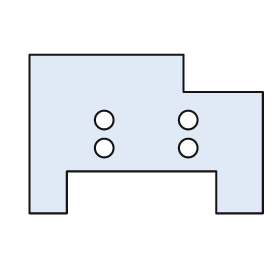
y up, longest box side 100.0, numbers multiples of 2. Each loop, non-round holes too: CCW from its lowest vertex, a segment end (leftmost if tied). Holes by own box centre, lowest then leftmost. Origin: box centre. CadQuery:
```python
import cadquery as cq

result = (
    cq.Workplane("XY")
    .moveTo(-50.0, -34.0)
    .lineTo(-34.0, -34.0)
    .lineTo(-34.0, -16.0)
    .lineTo(30.0, -16.0)
    .lineTo(30.0, -34.0)
    .lineTo(50.0, -34.0)
    .lineTo(50.0, 18.0)
    .lineTo(16.0, 18.0)
    .lineTo(16.0, 34.0)
    .lineTo(-50.0, 34.0)
    .close()
    .moveTo(-18.0, -6.0)
    .circle(4.0)
    .moveTo(18.0, -6.0)
    .circle(4.0)
    .moveTo(-18.0, 6.0)
    .circle(4.0)
    .moveTo(18.0, 6.0)
    .circle(4.0)
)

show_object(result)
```